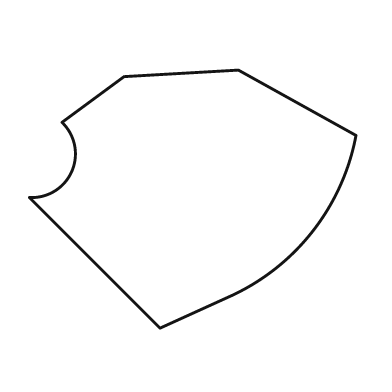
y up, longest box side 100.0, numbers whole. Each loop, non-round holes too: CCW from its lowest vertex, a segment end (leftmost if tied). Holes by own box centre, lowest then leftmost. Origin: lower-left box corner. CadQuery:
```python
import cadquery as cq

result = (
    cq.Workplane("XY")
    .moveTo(40.0, 0.0)
    .lineTo(62.0, 10.0)
    .threePointArc((87.0, 30.0), (100.0, 59.0))
    .lineTo(64.0, 79.0)
    .lineTo(29.0, 77.0)
    .lineTo(10.0, 63.0)
    .threePointArc((13.0, 48.0), (0.0, 40.0))
    .close()
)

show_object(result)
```